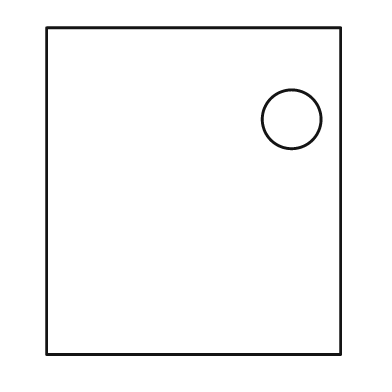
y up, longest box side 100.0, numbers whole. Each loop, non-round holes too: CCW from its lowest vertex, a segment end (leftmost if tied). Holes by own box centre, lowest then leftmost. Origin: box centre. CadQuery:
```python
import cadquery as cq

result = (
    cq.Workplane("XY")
    .moveTo(-45.0, -50.0)
    .lineTo(45.0, -50.0)
    .lineTo(45.0, 50.0)
    .lineTo(-45.0, 50.0)
    .close()
    .moveTo(30.0, 22.0)
    .circle(9.0)
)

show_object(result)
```